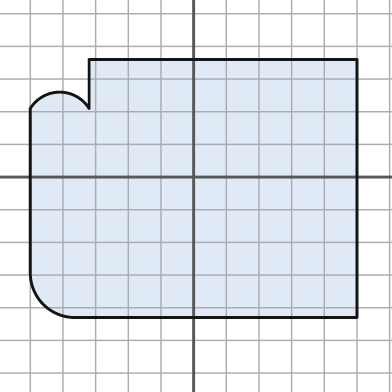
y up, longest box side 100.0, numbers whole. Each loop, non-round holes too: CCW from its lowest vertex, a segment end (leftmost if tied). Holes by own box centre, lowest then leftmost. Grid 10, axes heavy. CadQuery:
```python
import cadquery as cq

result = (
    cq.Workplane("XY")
    .moveTo(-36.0, -43.0)
    .lineTo(50.0, -43.0)
    .lineTo(50.0, 36.0)
    .lineTo(-32.0, 36.0)
    .lineTo(-32.0, 21.0)
    .threePointArc((-41.0, 26.0), (-50.0, 21.0))
    .lineTo(-50.0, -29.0)
    .threePointArc((-46.0, -39.0), (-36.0, -43.0))
    .close()
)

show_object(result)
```